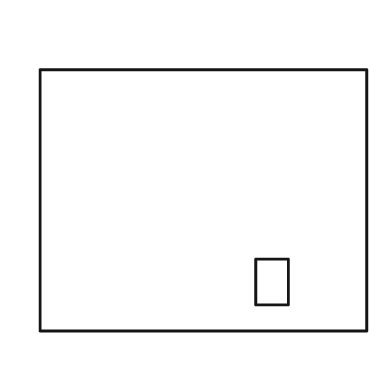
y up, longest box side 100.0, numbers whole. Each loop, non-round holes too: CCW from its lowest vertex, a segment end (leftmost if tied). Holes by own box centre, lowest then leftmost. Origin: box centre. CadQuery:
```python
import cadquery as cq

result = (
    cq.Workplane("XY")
    .moveTo(-50.0, -40.0)
    .lineTo(50.0, -40.0)
    .lineTo(50.0, 40.0)
    .lineTo(-50.0, 40.0)
    .close()
    .moveTo(16.0, -32.0)
    .lineTo(26.0, -32.0)
    .lineTo(26.0, -18.0)
    .lineTo(16.0, -18.0)
    .close()
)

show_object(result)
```